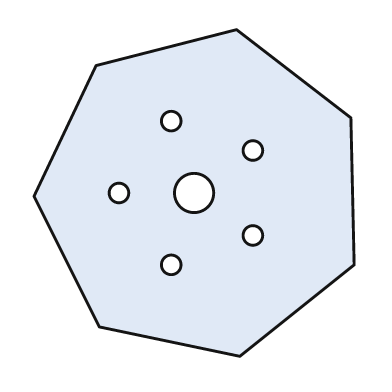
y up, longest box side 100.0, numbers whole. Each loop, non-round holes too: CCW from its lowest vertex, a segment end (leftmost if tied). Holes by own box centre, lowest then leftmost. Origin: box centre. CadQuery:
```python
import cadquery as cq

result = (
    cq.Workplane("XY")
    .moveTo(14.0, -50.0)
    .lineTo(49.0, -22.0)
    .lineTo(48.0, 23.0)
    .lineTo(13.0, 50.0)
    .lineTo(-30.0, 39.0)
    .lineTo(-49.0, -1.0)
    .lineTo(-29.0, -41.0)
    .close()
    .moveTo(-7.0, -22.0)
    .circle(3.0)
    .moveTo(18.0, -13.0)
    .circle(3.0)
    .moveTo(-23.0, 0.0)
    .circle(3.0)
    .moveTo(0.0, 0.0)
    .circle(6.0)
    .moveTo(18.0, 13.0)
    .circle(3.0)
    .moveTo(-7.0, 22.0)
    .circle(3.0)
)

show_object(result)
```